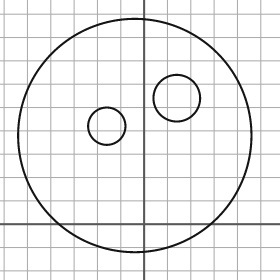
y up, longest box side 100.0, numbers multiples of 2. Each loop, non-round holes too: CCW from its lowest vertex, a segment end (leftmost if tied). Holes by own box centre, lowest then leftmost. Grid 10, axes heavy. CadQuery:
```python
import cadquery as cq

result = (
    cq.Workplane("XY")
    .moveTo(-4.0, 38.0)
    .circle(50.0)
    .moveTo(-16.0, 42.0)
    .circle(8.0)
    .moveTo(14.0, 54.0)
    .circle(10.0)
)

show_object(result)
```